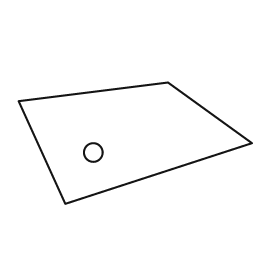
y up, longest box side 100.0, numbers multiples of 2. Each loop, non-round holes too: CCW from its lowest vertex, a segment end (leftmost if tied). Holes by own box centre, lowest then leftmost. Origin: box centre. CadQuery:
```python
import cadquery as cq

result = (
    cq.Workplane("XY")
    .moveTo(-30.0, -26.0)
    .lineTo(50.0, 0.0)
    .lineTo(14.0, 26.0)
    .lineTo(-50.0, 18.0)
    .close()
    .moveTo(-18.0, -4.0)
    .circle(4.0)
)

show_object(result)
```